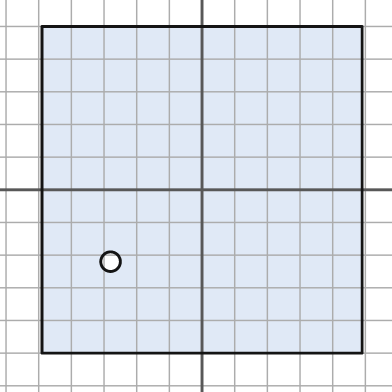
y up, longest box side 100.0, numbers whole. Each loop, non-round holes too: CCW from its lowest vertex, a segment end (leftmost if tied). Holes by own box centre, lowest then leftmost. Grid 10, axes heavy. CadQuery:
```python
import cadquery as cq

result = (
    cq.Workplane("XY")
    .moveTo(-49.0, -50.0)
    .lineTo(49.0, -50.0)
    .lineTo(49.0, 50.0)
    .lineTo(-49.0, 50.0)
    .close()
    .moveTo(-28.0, -22.0)
    .circle(3.0)
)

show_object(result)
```